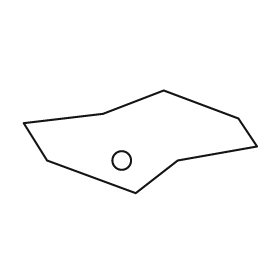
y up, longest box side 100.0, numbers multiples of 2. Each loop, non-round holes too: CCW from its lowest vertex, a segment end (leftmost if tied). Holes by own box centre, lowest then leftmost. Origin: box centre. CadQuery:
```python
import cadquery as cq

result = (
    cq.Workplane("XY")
    .moveTo(-2.0, -22.0)
    .lineTo(16.0, -8.0)
    .lineTo(50.0, -2.0)
    .lineTo(42.0, 10.0)
    .lineTo(10.0, 22.0)
    .lineTo(-16.0, 12.0)
    .lineTo(-50.0, 8.0)
    .lineTo(-40.0, -8.0)
    .close()
    .moveTo(-8.0, -8.0)
    .circle(4.0)
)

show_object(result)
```